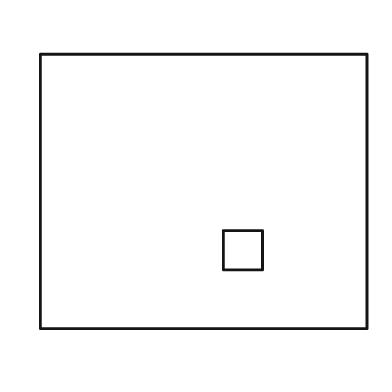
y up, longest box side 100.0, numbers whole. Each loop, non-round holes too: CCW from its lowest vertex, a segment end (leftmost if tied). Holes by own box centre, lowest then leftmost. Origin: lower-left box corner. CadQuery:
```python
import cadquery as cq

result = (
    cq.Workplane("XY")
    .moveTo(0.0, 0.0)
    .lineTo(100.0, 0.0)
    .lineTo(100.0, 84.0)
    .lineTo(0.0, 84.0)
    .close()
    .moveTo(56.0, 18.0)
    .lineTo(68.0, 18.0)
    .lineTo(68.0, 30.0)
    .lineTo(56.0, 30.0)
    .close()
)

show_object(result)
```